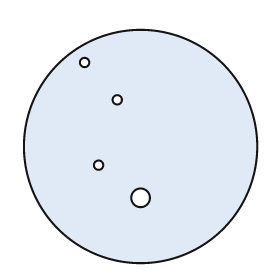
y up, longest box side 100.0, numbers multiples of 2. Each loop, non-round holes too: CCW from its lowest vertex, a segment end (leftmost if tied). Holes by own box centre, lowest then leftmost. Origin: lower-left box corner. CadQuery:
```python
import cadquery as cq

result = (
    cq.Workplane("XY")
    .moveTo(50.0, 50.0)
    .circle(50.0)
    .moveTo(50.0, 28.0)
    .circle(4.0)
    .moveTo(32.0, 42.0)
    .circle(2.0)
    .moveTo(40.0, 70.0)
    .circle(2.0)
    .moveTo(26.0, 86.0)
    .circle(2.0)
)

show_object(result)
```